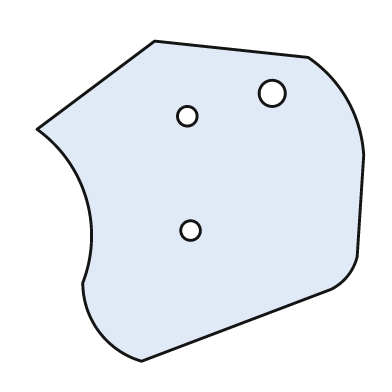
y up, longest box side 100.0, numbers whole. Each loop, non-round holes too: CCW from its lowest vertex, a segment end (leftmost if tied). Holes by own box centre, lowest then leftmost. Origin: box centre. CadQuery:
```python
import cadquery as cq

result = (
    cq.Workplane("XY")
    .moveTo(-18.0, -49.0)
    .lineTo(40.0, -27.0)
    .threePointArc((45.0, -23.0), (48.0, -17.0))
    .lineTo(50.0, 14.0)
    .threePointArc((45.0, 31.0), (33.0, 44.0))
    .lineTo(-14.0, 49.0)
    .lineTo(-50.0, 22.0)
    .threePointArc((-35.0, 1.0), (-36.0, -25.0))
    .threePointArc((-31.0, -40.0), (-18.0, -49.0))
    .close()
    .moveTo(-3.0, -9.0)
    .circle(3.0)
    .moveTo(-4.0, 26.0)
    .circle(3.0)
    .moveTo(22.0, 33.0)
    .circle(4.0)
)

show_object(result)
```